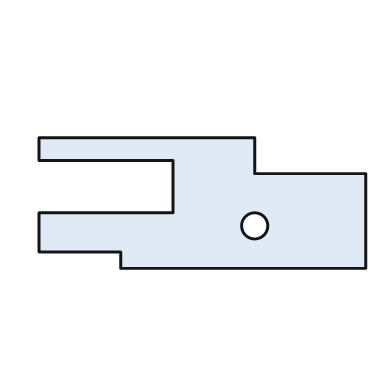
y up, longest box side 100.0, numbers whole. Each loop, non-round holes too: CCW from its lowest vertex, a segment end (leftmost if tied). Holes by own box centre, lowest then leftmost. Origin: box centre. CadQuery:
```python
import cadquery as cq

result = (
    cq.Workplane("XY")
    .moveTo(-25.0, -20.0)
    .lineTo(50.0, -20.0)
    .lineTo(50.0, 9.0)
    .lineTo(16.0, 9.0)
    .lineTo(16.0, 20.0)
    .lineTo(-50.0, 20.0)
    .lineTo(-50.0, 13.0)
    .lineTo(-9.0, 13.0)
    .lineTo(-9.0, -3.0)
    .lineTo(-50.0, -3.0)
    .lineTo(-50.0, -15.0)
    .lineTo(-25.0, -15.0)
    .close()
    .moveTo(16.0, -7.0)
    .circle(4.0)
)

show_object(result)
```